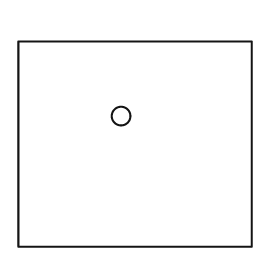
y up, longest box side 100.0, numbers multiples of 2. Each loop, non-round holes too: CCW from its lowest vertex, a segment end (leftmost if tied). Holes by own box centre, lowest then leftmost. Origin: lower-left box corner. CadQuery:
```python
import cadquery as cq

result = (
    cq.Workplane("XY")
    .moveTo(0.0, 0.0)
    .lineTo(100.0, 0.0)
    .lineTo(100.0, 88.0)
    .lineTo(0.0, 88.0)
    .close()
    .moveTo(44.0, 56.0)
    .circle(4.0)
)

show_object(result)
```